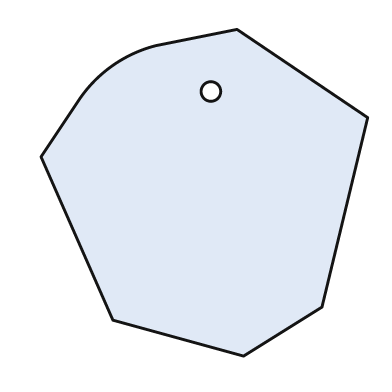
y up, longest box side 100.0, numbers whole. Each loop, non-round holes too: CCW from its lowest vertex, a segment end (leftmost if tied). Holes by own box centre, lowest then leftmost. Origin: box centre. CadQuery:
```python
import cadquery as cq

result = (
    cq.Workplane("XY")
    .moveTo(12.0, -50.0)
    .lineTo(36.0, -35.0)
    .lineTo(50.0, 23.0)
    .lineTo(10.0, 50.0)
    .lineTo(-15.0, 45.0)
    .threePointArc((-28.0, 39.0), (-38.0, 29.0))
    .lineTo(-50.0, 11.0)
    .lineTo(-28.0, -39.0)
    .close()
    .moveTo(2.0, 31.0)
    .circle(3.0)
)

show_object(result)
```